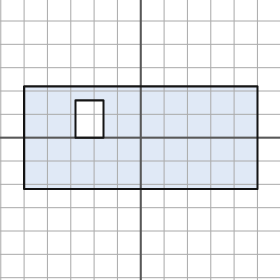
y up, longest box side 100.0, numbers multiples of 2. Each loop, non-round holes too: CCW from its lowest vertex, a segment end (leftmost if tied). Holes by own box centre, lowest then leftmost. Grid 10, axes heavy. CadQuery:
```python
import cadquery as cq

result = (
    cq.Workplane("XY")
    .moveTo(-50.0, -22.0)
    .lineTo(50.0, -22.0)
    .lineTo(50.0, 22.0)
    .lineTo(-50.0, 22.0)
    .close()
    .moveTo(-28.0, 0.0)
    .lineTo(-16.0, 0.0)
    .lineTo(-16.0, 16.0)
    .lineTo(-28.0, 16.0)
    .close()
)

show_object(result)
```